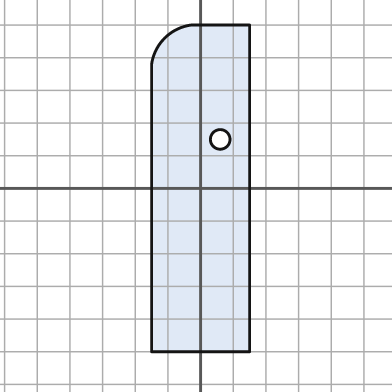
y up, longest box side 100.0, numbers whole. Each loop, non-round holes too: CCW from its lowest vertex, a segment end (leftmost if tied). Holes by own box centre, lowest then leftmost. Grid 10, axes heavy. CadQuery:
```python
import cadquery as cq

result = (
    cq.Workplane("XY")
    .moveTo(-15.0, -50.0)
    .lineTo(15.0, -50.0)
    .lineTo(15.0, 50.0)
    .lineTo(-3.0, 50.0)
    .threePointArc((-11.0, 46.0), (-15.0, 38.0))
    .close()
    .moveTo(6.0, 15.0)
    .circle(3.0)
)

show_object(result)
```